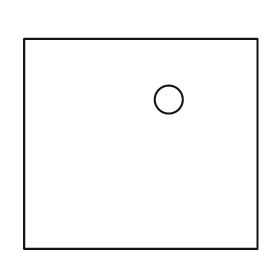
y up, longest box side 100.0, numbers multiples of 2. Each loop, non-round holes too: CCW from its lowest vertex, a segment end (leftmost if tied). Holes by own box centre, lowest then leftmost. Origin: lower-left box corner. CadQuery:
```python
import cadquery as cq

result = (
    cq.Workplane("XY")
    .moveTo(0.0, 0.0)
    .lineTo(100.0, 0.0)
    .lineTo(100.0, 90.0)
    .lineTo(0.0, 90.0)
    .close()
    .moveTo(62.0, 64.0)
    .circle(6.0)
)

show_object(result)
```